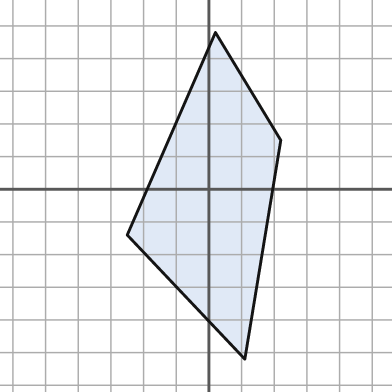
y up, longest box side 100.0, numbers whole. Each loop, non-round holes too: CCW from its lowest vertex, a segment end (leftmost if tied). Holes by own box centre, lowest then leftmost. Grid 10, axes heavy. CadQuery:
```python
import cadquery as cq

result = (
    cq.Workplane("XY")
    .moveTo(11.0, -52.0)
    .lineTo(22.0, 15.0)
    .lineTo(2.0, 48.0)
    .lineTo(-25.0, -14.0)
    .close()
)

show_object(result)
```